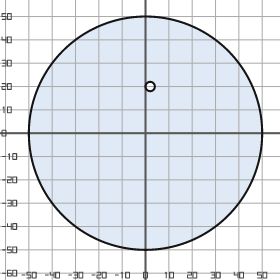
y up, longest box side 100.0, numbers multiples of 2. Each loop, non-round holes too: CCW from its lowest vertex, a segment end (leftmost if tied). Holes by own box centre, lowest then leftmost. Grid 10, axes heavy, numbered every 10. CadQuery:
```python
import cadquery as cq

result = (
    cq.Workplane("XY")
    .moveTo(0.0, 0.0)
    .circle(50.0)
    .moveTo(2.0, 20.0)
    .circle(2.0)
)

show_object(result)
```